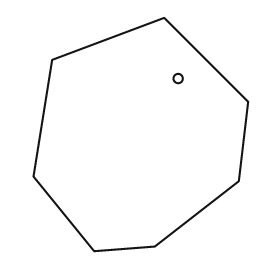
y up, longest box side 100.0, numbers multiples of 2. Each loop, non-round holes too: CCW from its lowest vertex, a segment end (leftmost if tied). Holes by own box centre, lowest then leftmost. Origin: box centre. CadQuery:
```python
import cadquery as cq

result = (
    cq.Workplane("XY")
    .moveTo(-20.0, -50.0)
    .lineTo(6.0, -48.0)
    .lineTo(42.0, -20.0)
    .lineTo(46.0, 14.0)
    .lineTo(10.0, 50.0)
    .lineTo(-38.0, 32.0)
    .lineTo(-46.0, -18.0)
    .close()
    .moveTo(16.0, 24.0)
    .circle(2.0)
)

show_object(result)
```